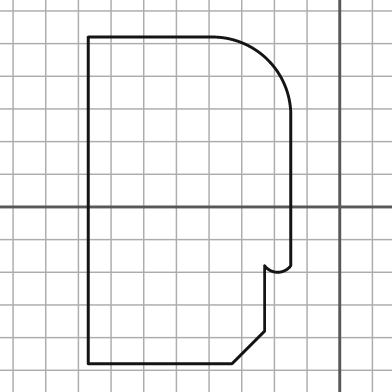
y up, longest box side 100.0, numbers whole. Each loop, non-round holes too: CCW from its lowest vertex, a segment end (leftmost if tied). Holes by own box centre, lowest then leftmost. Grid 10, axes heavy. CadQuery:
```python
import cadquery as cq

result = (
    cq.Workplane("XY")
    .moveTo(-77.0, -48.0)
    .lineTo(-33.0, -48.0)
    .lineTo(-23.0, -38.0)
    .lineTo(-23.0, -18.0)
    .threePointArc((-19.0, -20.0), (-15.0, -18.0))
    .lineTo(-15.0, 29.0)
    .threePointArc((-22.0, 45.0), (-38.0, 52.0))
    .lineTo(-77.0, 52.0)
    .close()
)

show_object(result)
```